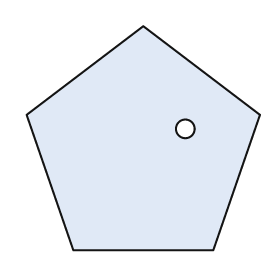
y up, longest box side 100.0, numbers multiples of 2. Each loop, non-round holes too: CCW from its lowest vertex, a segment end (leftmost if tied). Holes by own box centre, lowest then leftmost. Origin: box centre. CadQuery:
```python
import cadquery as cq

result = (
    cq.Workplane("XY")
    .moveTo(-30.0, -48.0)
    .lineTo(30.0, -48.0)
    .lineTo(50.0, 10.0)
    .lineTo(0.0, 48.0)
    .lineTo(-50.0, 10.0)
    .close()
    .moveTo(18.0, 4.0)
    .circle(4.0)
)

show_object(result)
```